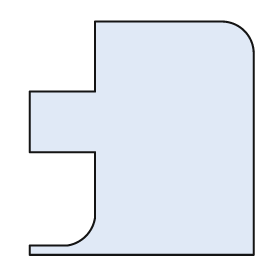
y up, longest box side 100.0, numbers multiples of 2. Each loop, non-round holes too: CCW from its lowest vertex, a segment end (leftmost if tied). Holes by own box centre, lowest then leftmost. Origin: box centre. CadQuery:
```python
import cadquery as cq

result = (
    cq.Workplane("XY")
    .moveTo(-48.0, -50.0)
    .lineTo(48.0, -50.0)
    .lineTo(48.0, 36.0)
    .threePointArc((44.0, 46.0), (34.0, 50.0))
    .lineTo(-20.0, 50.0)
    .lineTo(-20.0, 20.0)
    .lineTo(-48.0, 20.0)
    .lineTo(-48.0, -6.0)
    .lineTo(-20.0, -6.0)
    .lineTo(-20.0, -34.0)
    .threePointArc((-24.0, -42.0), (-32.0, -46.0))
    .lineTo(-48.0, -46.0)
    .close()
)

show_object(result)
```